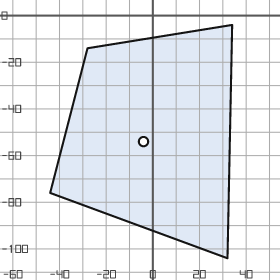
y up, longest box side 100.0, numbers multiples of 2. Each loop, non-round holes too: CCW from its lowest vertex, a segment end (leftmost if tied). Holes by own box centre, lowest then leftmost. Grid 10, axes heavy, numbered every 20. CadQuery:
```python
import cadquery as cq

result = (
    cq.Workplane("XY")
    .moveTo(32.0, -104.0)
    .lineTo(34.0, -4.0)
    .lineTo(-28.0, -14.0)
    .lineTo(-44.0, -76.0)
    .close()
    .moveTo(-4.0, -54.0)
    .circle(2.0)
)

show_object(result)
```